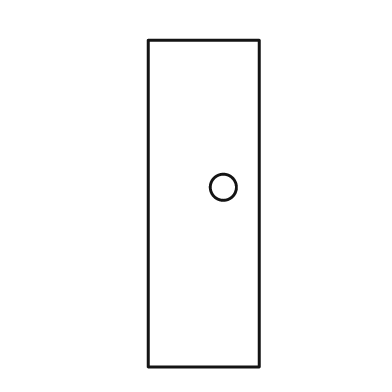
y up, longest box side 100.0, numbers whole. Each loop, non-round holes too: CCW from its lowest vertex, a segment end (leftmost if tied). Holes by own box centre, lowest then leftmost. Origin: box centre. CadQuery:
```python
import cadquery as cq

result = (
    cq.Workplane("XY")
    .moveTo(-17.0, -50.0)
    .lineTo(17.0, -50.0)
    .lineTo(17.0, 50.0)
    .lineTo(-17.0, 50.0)
    .close()
    .moveTo(6.0, 5.0)
    .circle(4.0)
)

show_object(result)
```